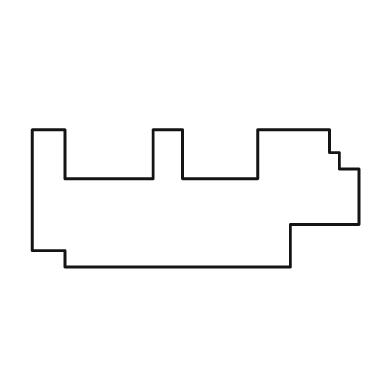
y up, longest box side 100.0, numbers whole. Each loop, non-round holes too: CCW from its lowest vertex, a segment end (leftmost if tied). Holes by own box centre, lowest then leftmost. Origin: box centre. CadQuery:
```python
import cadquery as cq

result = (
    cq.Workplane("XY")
    .moveTo(-40.0, -21.0)
    .lineTo(29.0, -21.0)
    .lineTo(29.0, -8.0)
    .lineTo(50.0, -8.0)
    .lineTo(50.0, 9.0)
    .lineTo(44.0, 9.0)
    .lineTo(44.0, 14.0)
    .lineTo(41.0, 14.0)
    .lineTo(41.0, 21.0)
    .lineTo(19.0, 21.0)
    .lineTo(19.0, 6.0)
    .lineTo(-4.0, 6.0)
    .lineTo(-4.0, 21.0)
    .lineTo(-13.0, 21.0)
    .lineTo(-13.0, 6.0)
    .lineTo(-40.0, 6.0)
    .lineTo(-40.0, 21.0)
    .lineTo(-50.0, 21.0)
    .lineTo(-50.0, -16.0)
    .lineTo(-40.0, -16.0)
    .close()
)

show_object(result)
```